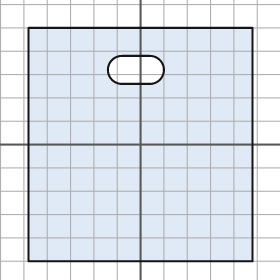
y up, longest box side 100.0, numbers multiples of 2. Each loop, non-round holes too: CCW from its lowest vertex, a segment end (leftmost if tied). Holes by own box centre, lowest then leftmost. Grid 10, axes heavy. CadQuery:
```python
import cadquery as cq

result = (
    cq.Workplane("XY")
    .moveTo(-48.0, -50.0)
    .lineTo(48.0, -50.0)
    .lineTo(48.0, 50.0)
    .lineTo(-48.0, 50.0)
    .close()
    .moveTo(-8.0, 26.0)
    .lineTo(4.0, 26.0)
    .threePointArc((10.0, 32.0), (4.0, 38.0))
    .lineTo(-8.0, 38.0)
    .threePointArc((-14.0, 32.0), (-8.0, 26.0))
    .close()
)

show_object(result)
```